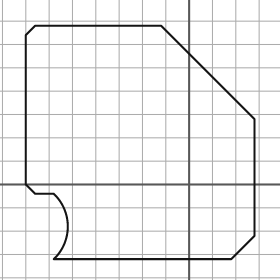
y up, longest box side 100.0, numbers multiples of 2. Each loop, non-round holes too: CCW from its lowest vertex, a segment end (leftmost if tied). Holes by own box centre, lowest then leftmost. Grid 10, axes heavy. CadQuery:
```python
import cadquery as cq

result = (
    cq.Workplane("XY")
    .moveTo(-58.0, -32.0)
    .lineTo(18.0, -32.0)
    .lineTo(28.0, -22.0)
    .lineTo(28.0, 28.0)
    .lineTo(-12.0, 68.0)
    .lineTo(-66.0, 68.0)
    .lineTo(-70.0, 64.0)
    .lineTo(-70.0, 0.0)
    .lineTo(-66.0, -4.0)
    .lineTo(-58.0, -4.0)
    .threePointArc((-52.0, -18.0), (-58.0, -32.0))
    .close()
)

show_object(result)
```